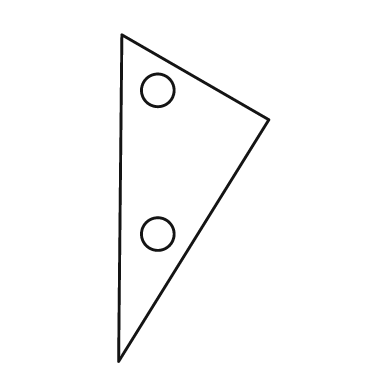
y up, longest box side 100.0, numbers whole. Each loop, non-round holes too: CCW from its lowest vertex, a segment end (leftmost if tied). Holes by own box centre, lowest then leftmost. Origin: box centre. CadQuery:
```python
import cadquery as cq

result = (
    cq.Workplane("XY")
    .moveTo(-23.0, -50.0)
    .lineTo(23.0, 24.0)
    .lineTo(-22.0, 50.0)
    .close()
    .moveTo(-11.0, -11.0)
    .circle(5.0)
    .moveTo(-11.0, 33.0)
    .circle(5.0)
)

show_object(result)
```